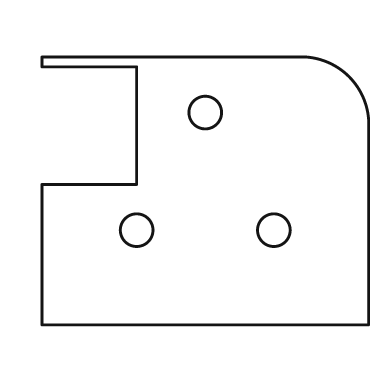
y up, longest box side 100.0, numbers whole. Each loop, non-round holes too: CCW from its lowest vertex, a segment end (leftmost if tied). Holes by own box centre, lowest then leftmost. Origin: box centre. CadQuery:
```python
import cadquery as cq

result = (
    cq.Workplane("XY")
    .moveTo(-50.0, -41.0)
    .lineTo(50.0, -41.0)
    .lineTo(50.0, 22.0)
    .threePointArc((44.0, 35.0), (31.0, 41.0))
    .lineTo(-50.0, 41.0)
    .lineTo(-50.0, 38.0)
    .lineTo(-21.0, 38.0)
    .lineTo(-21.0, 2.0)
    .lineTo(-50.0, 2.0)
    .close()
    .moveTo(-21.0, -12.0)
    .circle(5.0)
    .moveTo(21.0, -12.0)
    .circle(5.0)
    .moveTo(0.0, 24.0)
    .circle(5.0)
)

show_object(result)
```